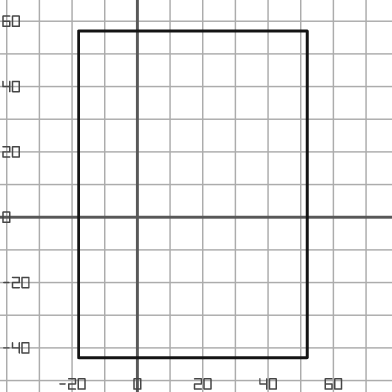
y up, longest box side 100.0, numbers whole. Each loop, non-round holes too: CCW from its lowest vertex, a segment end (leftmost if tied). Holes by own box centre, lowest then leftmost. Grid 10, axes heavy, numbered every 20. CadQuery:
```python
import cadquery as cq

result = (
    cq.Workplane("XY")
    .moveTo(-18.0, -43.0)
    .lineTo(52.0, -43.0)
    .lineTo(52.0, 57.0)
    .lineTo(-18.0, 57.0)
    .close()
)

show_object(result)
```